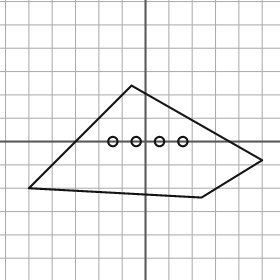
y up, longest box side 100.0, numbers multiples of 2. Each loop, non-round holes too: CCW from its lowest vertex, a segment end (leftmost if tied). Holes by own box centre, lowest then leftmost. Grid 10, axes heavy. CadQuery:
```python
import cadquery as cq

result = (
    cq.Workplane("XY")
    .moveTo(24.0, -24.0)
    .lineTo(50.0, -8.0)
    .lineTo(-6.0, 24.0)
    .lineTo(-50.0, -20.0)
    .close()
    .moveTo(-14.0, 0.0)
    .circle(2.0)
    .moveTo(-4.0, 0.0)
    .circle(2.0)
    .moveTo(6.0, 0.0)
    .circle(2.0)
    .moveTo(16.0, 0.0)
    .circle(2.0)
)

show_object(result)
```